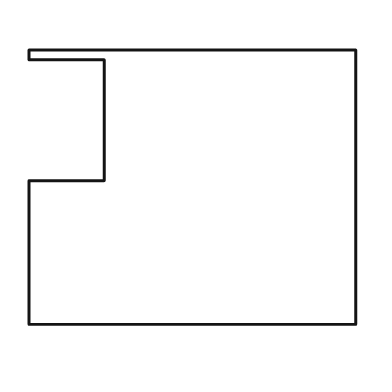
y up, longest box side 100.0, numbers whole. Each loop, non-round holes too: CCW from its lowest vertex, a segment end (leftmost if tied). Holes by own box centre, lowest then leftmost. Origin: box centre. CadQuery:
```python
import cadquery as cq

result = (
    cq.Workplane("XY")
    .moveTo(-50.0, -42.0)
    .lineTo(50.0, -42.0)
    .lineTo(50.0, 42.0)
    .lineTo(-50.0, 42.0)
    .lineTo(-50.0, 39.0)
    .lineTo(-27.0, 39.0)
    .lineTo(-27.0, 2.0)
    .lineTo(-50.0, 2.0)
    .close()
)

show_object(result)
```